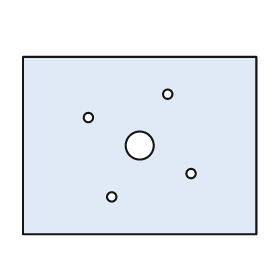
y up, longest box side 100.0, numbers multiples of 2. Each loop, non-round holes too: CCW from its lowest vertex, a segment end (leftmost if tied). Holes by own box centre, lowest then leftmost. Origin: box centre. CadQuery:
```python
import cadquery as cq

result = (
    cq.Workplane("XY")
    .moveTo(-50.0, -38.0)
    .lineTo(50.0, -38.0)
    .lineTo(50.0, 38.0)
    .lineTo(-50.0, 38.0)
    .close()
    .moveTo(-12.0, -22.0)
    .circle(2.0)
    .moveTo(22.0, -12.0)
    .circle(2.0)
    .moveTo(0.0, 0.0)
    .circle(6.0)
    .moveTo(-22.0, 12.0)
    .circle(2.0)
    .moveTo(12.0, 22.0)
    .circle(2.0)
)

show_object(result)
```